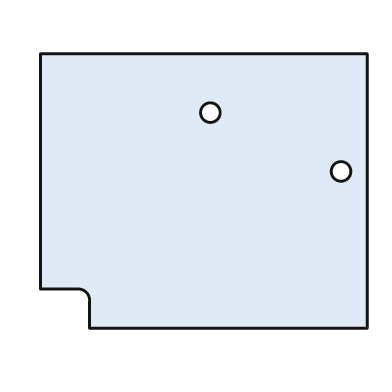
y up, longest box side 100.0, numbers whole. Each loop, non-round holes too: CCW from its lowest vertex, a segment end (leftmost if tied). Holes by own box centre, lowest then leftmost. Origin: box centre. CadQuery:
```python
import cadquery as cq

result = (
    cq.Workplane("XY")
    .moveTo(-35.0, -42.0)
    .lineTo(50.0, -42.0)
    .lineTo(50.0, 42.0)
    .lineTo(-50.0, 42.0)
    .lineTo(-50.0, -30.0)
    .lineTo(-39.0, -30.0)
    .threePointArc((-36.0, -31.0), (-35.0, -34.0))
    .close()
    .moveTo(42.0, 6.0)
    .circle(3.0)
    .moveTo(2.0, 24.0)
    .circle(3.0)
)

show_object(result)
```